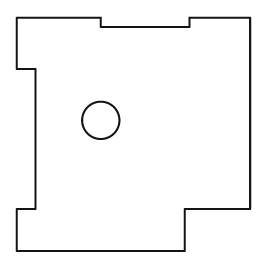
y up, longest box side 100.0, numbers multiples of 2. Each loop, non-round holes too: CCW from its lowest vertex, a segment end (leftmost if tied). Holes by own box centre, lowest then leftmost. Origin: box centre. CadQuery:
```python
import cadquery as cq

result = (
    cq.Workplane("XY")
    .moveTo(-50.0, -50.0)
    .lineTo(22.0, -50.0)
    .lineTo(22.0, -32.0)
    .lineTo(50.0, -32.0)
    .lineTo(50.0, 50.0)
    .lineTo(24.0, 50.0)
    .lineTo(24.0, 46.0)
    .lineTo(-14.0, 46.0)
    .lineTo(-14.0, 50.0)
    .lineTo(-50.0, 50.0)
    .lineTo(-50.0, 28.0)
    .lineTo(-42.0, 28.0)
    .lineTo(-42.0, -32.0)
    .lineTo(-50.0, -32.0)
    .close()
    .moveTo(-14.0, 6.0)
    .circle(8.0)
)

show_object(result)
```